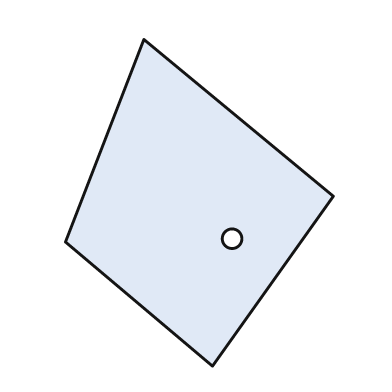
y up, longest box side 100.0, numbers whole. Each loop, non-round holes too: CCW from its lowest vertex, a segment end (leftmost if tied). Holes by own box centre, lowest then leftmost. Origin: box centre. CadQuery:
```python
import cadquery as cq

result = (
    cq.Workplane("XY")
    .moveTo(4.0, -50.0)
    .lineTo(41.0, 2.0)
    .lineTo(-17.0, 50.0)
    .lineTo(-41.0, -12.0)
    .close()
    .moveTo(10.0, -11.0)
    .circle(3.0)
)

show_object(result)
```